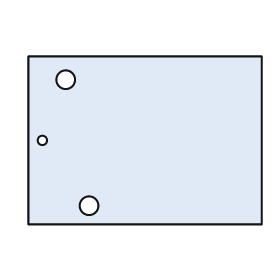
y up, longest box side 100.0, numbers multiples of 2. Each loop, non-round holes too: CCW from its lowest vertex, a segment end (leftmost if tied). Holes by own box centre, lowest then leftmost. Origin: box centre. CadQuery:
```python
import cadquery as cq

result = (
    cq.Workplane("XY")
    .moveTo(-50.0, -36.0)
    .lineTo(50.0, -36.0)
    .lineTo(50.0, 36.0)
    .lineTo(-50.0, 36.0)
    .close()
    .moveTo(-24.0, -28.0)
    .circle(4.0)
    .moveTo(-44.0, 0.0)
    .circle(2.0)
    .moveTo(-34.0, 26.0)
    .circle(4.0)
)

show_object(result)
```